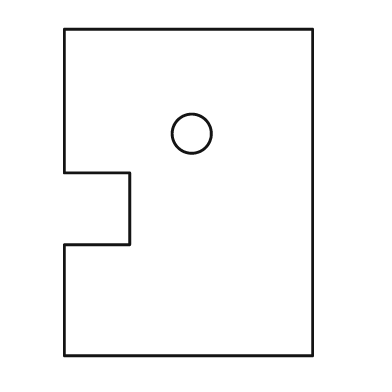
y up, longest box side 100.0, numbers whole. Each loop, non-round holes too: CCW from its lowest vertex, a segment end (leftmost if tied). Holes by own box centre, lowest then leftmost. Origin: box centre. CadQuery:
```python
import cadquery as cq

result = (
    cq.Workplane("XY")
    .moveTo(-38.0, -50.0)
    .lineTo(38.0, -50.0)
    .lineTo(38.0, 50.0)
    .lineTo(-38.0, 50.0)
    .lineTo(-38.0, 6.0)
    .lineTo(-18.0, 6.0)
    .lineTo(-18.0, -16.0)
    .lineTo(-38.0, -16.0)
    .close()
    .moveTo(1.0, 18.0)
    .circle(6.0)
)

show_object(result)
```